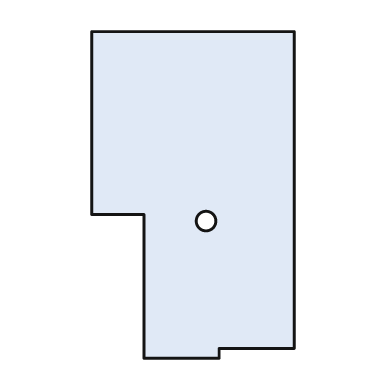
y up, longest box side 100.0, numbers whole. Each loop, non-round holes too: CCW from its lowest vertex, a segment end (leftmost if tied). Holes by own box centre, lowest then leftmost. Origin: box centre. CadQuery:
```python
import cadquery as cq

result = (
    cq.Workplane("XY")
    .moveTo(-15.0, -50.0)
    .lineTo(8.0, -50.0)
    .lineTo(8.0, -47.0)
    .lineTo(31.0, -47.0)
    .lineTo(31.0, 50.0)
    .lineTo(-31.0, 50.0)
    .lineTo(-31.0, -6.0)
    .lineTo(-15.0, -6.0)
    .close()
    .moveTo(4.0, -8.0)
    .circle(3.0)
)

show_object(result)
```